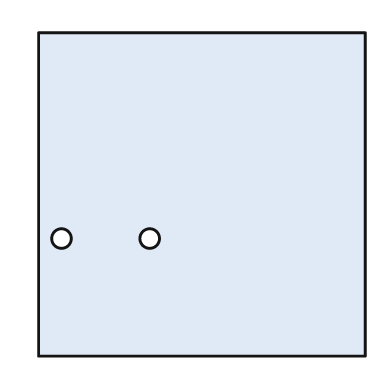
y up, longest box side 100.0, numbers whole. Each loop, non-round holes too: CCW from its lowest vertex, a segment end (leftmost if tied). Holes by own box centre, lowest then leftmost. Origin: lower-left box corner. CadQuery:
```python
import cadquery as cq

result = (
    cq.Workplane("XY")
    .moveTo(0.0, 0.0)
    .lineTo(100.0, 0.0)
    .lineTo(100.0, 99.0)
    .lineTo(0.0, 99.0)
    .close()
    .moveTo(7.0, 36.0)
    .circle(3.0)
    .moveTo(34.0, 36.0)
    .circle(3.0)
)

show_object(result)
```